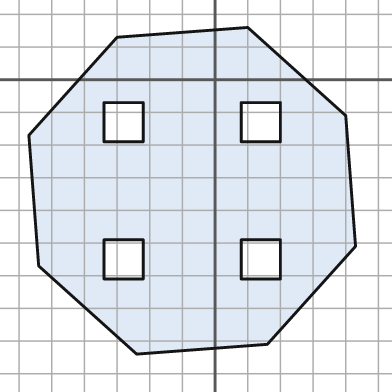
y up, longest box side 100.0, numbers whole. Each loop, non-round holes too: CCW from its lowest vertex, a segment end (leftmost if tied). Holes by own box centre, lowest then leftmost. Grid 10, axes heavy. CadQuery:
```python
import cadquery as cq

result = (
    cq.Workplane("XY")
    .moveTo(-24.0, -84.0)
    .lineTo(16.0, -81.0)
    .lineTo(43.0, -51.0)
    .lineTo(40.0, -11.0)
    .lineTo(10.0, 16.0)
    .lineTo(-30.0, 13.0)
    .lineTo(-57.0, -17.0)
    .lineTo(-54.0, -57.0)
    .close()
    .moveTo(-34.0, -61.0)
    .lineTo(-22.0, -61.0)
    .lineTo(-22.0, -49.0)
    .lineTo(-34.0, -49.0)
    .close()
    .moveTo(8.0, -61.0)
    .lineTo(20.0, -61.0)
    .lineTo(20.0, -49.0)
    .lineTo(8.0, -49.0)
    .close()
    .moveTo(-34.0, -19.0)
    .lineTo(-22.0, -19.0)
    .lineTo(-22.0, -7.0)
    .lineTo(-34.0, -7.0)
    .close()
    .moveTo(8.0, -19.0)
    .lineTo(20.0, -19.0)
    .lineTo(20.0, -7.0)
    .lineTo(8.0, -7.0)
    .close()
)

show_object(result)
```